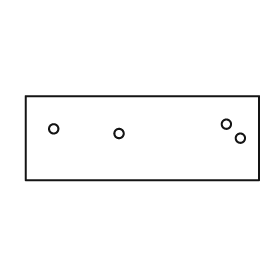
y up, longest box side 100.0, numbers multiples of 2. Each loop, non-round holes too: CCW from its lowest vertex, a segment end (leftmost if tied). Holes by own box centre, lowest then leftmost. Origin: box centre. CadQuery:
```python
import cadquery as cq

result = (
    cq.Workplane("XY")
    .moveTo(-50.0, -18.0)
    .lineTo(50.0, -18.0)
    .lineTo(50.0, 18.0)
    .lineTo(-50.0, 18.0)
    .close()
    .moveTo(42.0, 0.0)
    .circle(2.0)
    .moveTo(-10.0, 2.0)
    .circle(2.0)
    .moveTo(-38.0, 4.0)
    .circle(2.0)
    .moveTo(36.0, 6.0)
    .circle(2.0)
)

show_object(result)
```